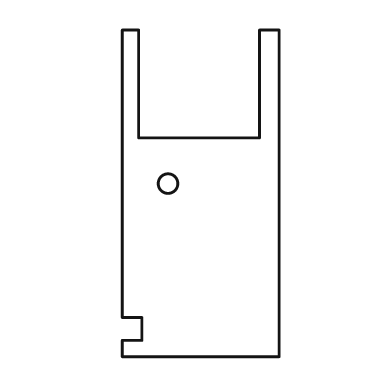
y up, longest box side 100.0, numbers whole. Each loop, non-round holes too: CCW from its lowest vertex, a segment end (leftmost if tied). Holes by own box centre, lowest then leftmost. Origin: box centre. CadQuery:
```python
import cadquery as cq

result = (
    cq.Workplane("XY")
    .moveTo(-24.0, -50.0)
    .lineTo(24.0, -50.0)
    .lineTo(24.0, 50.0)
    .lineTo(18.0, 50.0)
    .lineTo(18.0, 17.0)
    .lineTo(-19.0, 17.0)
    .lineTo(-19.0, 50.0)
    .lineTo(-24.0, 50.0)
    .lineTo(-24.0, -38.0)
    .lineTo(-18.0, -38.0)
    .lineTo(-18.0, -45.0)
    .lineTo(-24.0, -45.0)
    .close()
    .moveTo(-10.0, 3.0)
    .circle(3.0)
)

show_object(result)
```